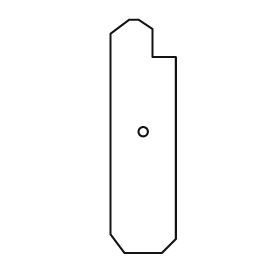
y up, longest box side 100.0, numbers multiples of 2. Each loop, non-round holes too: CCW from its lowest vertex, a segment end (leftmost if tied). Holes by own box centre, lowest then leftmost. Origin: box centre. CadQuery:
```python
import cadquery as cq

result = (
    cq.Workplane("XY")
    .moveTo(-8.0, -50.0)
    .lineTo(8.0, -50.0)
    .lineTo(14.0, -44.0)
    .lineTo(14.0, 34.0)
    .lineTo(4.0, 34.0)
    .lineTo(4.0, 46.0)
    .lineTo(-2.0, 50.0)
    .lineTo(-6.0, 50.0)
    .lineTo(-14.0, 44.0)
    .lineTo(-14.0, -42.0)
    .close()
    .moveTo(0.0, 2.0)
    .circle(2.0)
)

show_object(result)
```